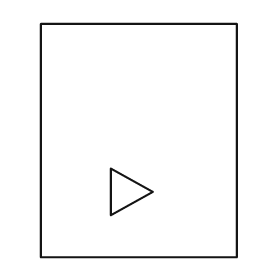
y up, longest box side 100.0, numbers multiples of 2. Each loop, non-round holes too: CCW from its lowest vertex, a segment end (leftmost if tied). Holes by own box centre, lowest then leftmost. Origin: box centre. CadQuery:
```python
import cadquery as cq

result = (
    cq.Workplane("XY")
    .moveTo(-42.0, -50.0)
    .lineTo(42.0, -50.0)
    .lineTo(42.0, 50.0)
    .lineTo(-42.0, 50.0)
    .close()
    .moveTo(-12.0, -32.0)
    .lineTo(6.0, -22.0)
    .lineTo(-12.0, -12.0)
    .close()
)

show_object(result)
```